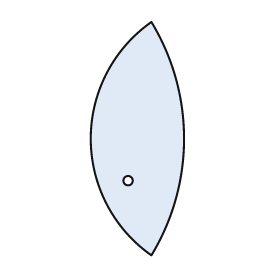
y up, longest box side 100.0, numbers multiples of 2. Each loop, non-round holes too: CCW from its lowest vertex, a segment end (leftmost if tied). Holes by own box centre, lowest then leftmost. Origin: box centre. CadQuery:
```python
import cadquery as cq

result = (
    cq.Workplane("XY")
    .moveTo(6.0, -50.0)
    .threePointArc((20.0, 0.0), (6.0, 50.0))
    .threePointArc((-20.0, 0.0), (6.0, -50.0))
    .close()
    .moveTo(-4.0, -18.0)
    .circle(2.0)
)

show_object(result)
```